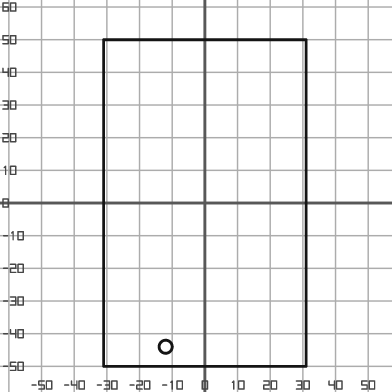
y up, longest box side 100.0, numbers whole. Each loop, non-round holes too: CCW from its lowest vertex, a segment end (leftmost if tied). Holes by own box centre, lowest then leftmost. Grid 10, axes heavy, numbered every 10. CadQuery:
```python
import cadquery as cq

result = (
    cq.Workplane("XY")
    .moveTo(-31.0, -50.0)
    .lineTo(31.0, -50.0)
    .lineTo(31.0, 50.0)
    .lineTo(-31.0, 50.0)
    .close()
    .moveTo(-12.0, -44.0)
    .circle(2.0)
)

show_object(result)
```